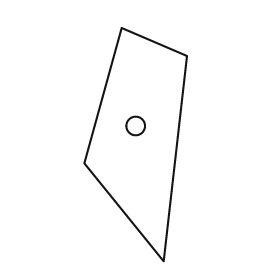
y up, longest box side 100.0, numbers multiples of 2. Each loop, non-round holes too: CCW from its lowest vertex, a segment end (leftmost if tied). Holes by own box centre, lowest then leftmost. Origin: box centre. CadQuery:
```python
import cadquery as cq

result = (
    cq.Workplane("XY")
    .moveTo(12.0, -50.0)
    .lineTo(22.0, 38.0)
    .lineTo(-6.0, 50.0)
    .lineTo(-22.0, -8.0)
    .close()
    .moveTo(0.0, 8.0)
    .circle(4.0)
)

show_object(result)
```